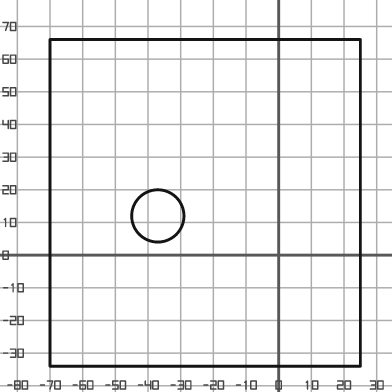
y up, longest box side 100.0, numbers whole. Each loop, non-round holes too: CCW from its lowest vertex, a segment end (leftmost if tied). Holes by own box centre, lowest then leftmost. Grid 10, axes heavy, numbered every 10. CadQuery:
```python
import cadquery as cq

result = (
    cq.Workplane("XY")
    .moveTo(-70.0, -34.0)
    .lineTo(25.0, -34.0)
    .lineTo(25.0, 66.0)
    .lineTo(-70.0, 66.0)
    .close()
    .moveTo(-37.0, 12.0)
    .circle(8.0)
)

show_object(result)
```